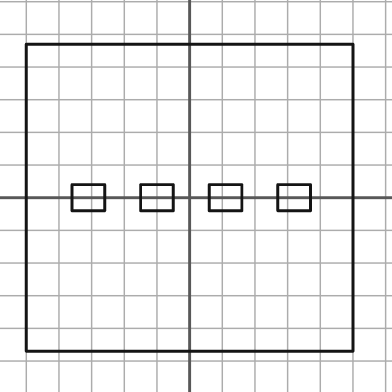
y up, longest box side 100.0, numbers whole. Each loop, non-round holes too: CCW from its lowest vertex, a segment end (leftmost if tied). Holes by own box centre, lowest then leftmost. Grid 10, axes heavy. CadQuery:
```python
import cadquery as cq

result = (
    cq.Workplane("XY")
    .moveTo(-50.0, -47.0)
    .lineTo(50.0, -47.0)
    .lineTo(50.0, 47.0)
    .lineTo(-50.0, 47.0)
    .close()
    .moveTo(-36.0, -4.0)
    .lineTo(-26.0, -4.0)
    .lineTo(-26.0, 4.0)
    .lineTo(-36.0, 4.0)
    .close()
    .moveTo(-15.0, -4.0)
    .lineTo(-5.0, -4.0)
    .lineTo(-5.0, 4.0)
    .lineTo(-15.0, 4.0)
    .close()
    .moveTo(6.0, -4.0)
    .lineTo(16.0, -4.0)
    .lineTo(16.0, 4.0)
    .lineTo(6.0, 4.0)
    .close()
    .moveTo(27.0, -4.0)
    .lineTo(37.0, -4.0)
    .lineTo(37.0, 4.0)
    .lineTo(27.0, 4.0)
    .close()
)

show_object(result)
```